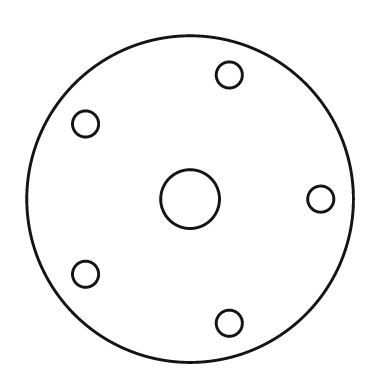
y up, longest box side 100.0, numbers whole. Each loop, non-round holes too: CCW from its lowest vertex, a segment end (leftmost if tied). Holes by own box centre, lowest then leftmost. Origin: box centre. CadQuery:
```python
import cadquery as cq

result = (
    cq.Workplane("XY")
    .moveTo(0.0, 0.0)
    .circle(50.0)
    .moveTo(12.0, -38.0)
    .circle(4.0)
    .moveTo(-32.0, -23.0)
    .circle(4.0)
    .moveTo(0.0, 0.0)
    .circle(9.0)
    .moveTo(40.0, 0.0)
    .circle(4.0)
    .moveTo(-32.0, 23.0)
    .circle(4.0)
    .moveTo(12.0, 38.0)
    .circle(4.0)
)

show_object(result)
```